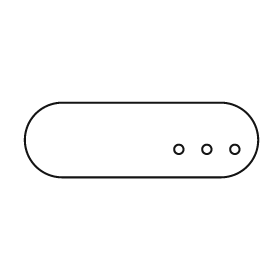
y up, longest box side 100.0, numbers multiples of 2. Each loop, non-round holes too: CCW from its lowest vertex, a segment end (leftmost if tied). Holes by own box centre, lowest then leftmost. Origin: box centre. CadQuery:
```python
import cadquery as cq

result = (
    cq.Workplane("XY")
    .moveTo(-34.0, -16.0)
    .lineTo(34.0, -16.0)
    .threePointArc((50.0, 0.0), (34.0, 16.0))
    .lineTo(-34.0, 16.0)
    .threePointArc((-50.0, 0.0), (-34.0, -16.0))
    .close()
    .moveTo(16.0, -4.0)
    .circle(2.0)
    .moveTo(28.0, -4.0)
    .circle(2.0)
    .moveTo(40.0, -4.0)
    .circle(2.0)
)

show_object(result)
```